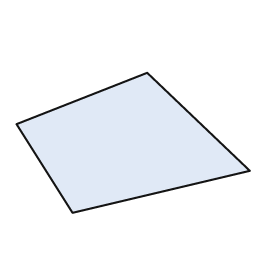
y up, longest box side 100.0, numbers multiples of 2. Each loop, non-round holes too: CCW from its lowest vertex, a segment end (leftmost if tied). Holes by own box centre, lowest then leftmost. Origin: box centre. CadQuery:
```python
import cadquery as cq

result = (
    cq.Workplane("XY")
    .moveTo(-26.0, -30.0)
    .lineTo(50.0, -12.0)
    .lineTo(6.0, 30.0)
    .lineTo(-50.0, 8.0)
    .close()
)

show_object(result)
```